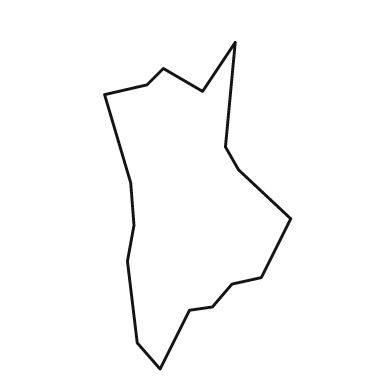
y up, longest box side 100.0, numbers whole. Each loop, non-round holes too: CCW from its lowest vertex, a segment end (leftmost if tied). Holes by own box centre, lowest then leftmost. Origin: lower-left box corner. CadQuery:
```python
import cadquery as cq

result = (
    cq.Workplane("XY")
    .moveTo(17.0, 0.0)
    .lineTo(26.0, 18.0)
    .lineTo(33.0, 19.0)
    .lineTo(39.0, 26.0)
    .lineTo(48.0, 28.0)
    .lineTo(57.0, 46.0)
    .lineTo(41.0, 61.0)
    .lineTo(37.0, 68.0)
    .lineTo(40.0, 100.0)
    .lineTo(30.0, 85.0)
    .lineTo(18.0, 92.0)
    .lineTo(13.0, 87.0)
    .lineTo(0.0, 84.0)
    .lineTo(8.0, 57.0)
    .lineTo(9.0, 44.0)
    .lineTo(7.0, 33.0)
    .lineTo(10.0, 8.0)
    .close()
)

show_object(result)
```